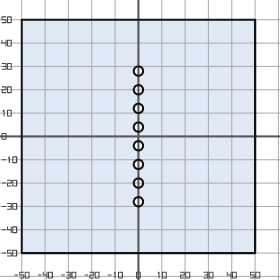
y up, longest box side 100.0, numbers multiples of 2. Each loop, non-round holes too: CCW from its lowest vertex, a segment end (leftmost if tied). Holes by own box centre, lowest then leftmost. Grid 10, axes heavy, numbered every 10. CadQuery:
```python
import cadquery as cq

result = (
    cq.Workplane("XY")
    .moveTo(-50.0, -50.0)
    .lineTo(50.0, -50.0)
    .lineTo(50.0, 50.0)
    .lineTo(-50.0, 50.0)
    .close()
    .moveTo(0.0, -28.0)
    .circle(2.0)
    .moveTo(0.0, -20.0)
    .circle(2.0)
    .moveTo(0.0, -12.0)
    .circle(2.0)
    .moveTo(0.0, -4.0)
    .circle(2.0)
    .moveTo(0.0, 4.0)
    .circle(2.0)
    .moveTo(0.0, 12.0)
    .circle(2.0)
    .moveTo(0.0, 20.0)
    .circle(2.0)
    .moveTo(0.0, 28.0)
    .circle(2.0)
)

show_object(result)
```